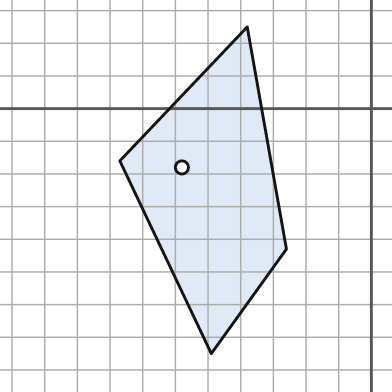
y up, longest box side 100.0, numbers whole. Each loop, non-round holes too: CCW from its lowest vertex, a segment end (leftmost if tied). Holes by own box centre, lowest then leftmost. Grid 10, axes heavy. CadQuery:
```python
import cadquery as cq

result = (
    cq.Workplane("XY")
    .moveTo(-49.0, -75.0)
    .lineTo(-26.0, -43.0)
    .lineTo(-38.0, 25.0)
    .lineTo(-77.0, -16.0)
    .close()
    .moveTo(-58.0, -18.0)
    .circle(2.0)
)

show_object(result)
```